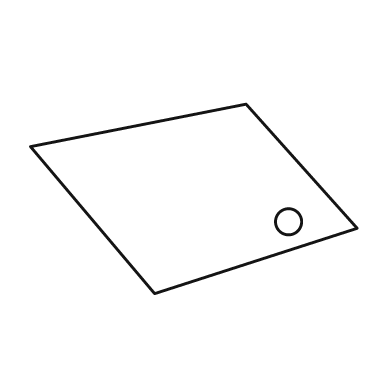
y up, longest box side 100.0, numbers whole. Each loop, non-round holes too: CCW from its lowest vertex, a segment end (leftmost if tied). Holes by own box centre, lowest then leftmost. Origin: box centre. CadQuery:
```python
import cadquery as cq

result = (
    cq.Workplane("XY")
    .moveTo(-12.0, -29.0)
    .lineTo(50.0, -9.0)
    .lineTo(16.0, 29.0)
    .lineTo(-50.0, 16.0)
    .close()
    .moveTo(29.0, -7.0)
    .circle(4.0)
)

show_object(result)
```